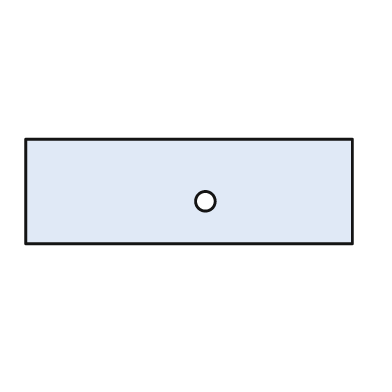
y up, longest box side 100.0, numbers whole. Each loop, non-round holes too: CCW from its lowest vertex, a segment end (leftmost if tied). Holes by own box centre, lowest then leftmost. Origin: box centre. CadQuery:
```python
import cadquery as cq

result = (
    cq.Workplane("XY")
    .moveTo(-50.0, -16.0)
    .lineTo(50.0, -16.0)
    .lineTo(50.0, 16.0)
    .lineTo(-50.0, 16.0)
    .close()
    .moveTo(5.0, -3.0)
    .circle(3.0)
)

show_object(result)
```